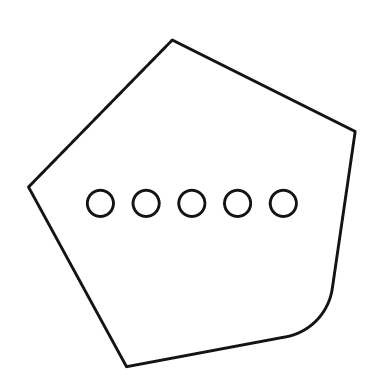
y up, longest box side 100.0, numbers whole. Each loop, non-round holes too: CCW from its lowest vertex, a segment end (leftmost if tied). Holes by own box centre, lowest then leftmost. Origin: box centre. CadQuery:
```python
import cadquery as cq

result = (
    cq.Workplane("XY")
    .moveTo(-20.0, -50.0)
    .lineTo(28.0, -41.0)
    .threePointArc((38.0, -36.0), (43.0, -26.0))
    .lineTo(50.0, 22.0)
    .lineTo(-6.0, 50.0)
    .lineTo(-50.0, 5.0)
    .close()
    .moveTo(-28.0, 0.0)
    .circle(4.0)
    .moveTo(-14.0, 0.0)
    .circle(4.0)
    .moveTo(0.0, 0.0)
    .circle(4.0)
    .moveTo(14.0, 0.0)
    .circle(4.0)
    .moveTo(28.0, 0.0)
    .circle(4.0)
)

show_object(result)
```